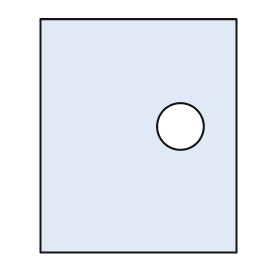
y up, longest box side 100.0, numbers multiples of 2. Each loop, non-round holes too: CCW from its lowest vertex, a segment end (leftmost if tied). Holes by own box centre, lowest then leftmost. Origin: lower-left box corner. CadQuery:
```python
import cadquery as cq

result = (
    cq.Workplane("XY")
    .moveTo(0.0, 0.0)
    .lineTo(84.0, 0.0)
    .lineTo(84.0, 100.0)
    .lineTo(0.0, 100.0)
    .close()
    .moveTo(60.0, 54.0)
    .circle(10.0)
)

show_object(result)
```